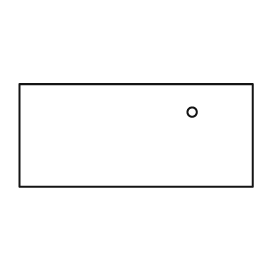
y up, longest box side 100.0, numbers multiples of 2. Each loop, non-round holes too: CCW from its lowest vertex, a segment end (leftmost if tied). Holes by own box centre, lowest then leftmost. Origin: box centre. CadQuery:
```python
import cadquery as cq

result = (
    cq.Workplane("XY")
    .moveTo(-50.0, -22.0)
    .lineTo(50.0, -22.0)
    .lineTo(50.0, 22.0)
    .lineTo(-50.0, 22.0)
    .close()
    .moveTo(24.0, 10.0)
    .circle(2.0)
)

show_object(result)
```